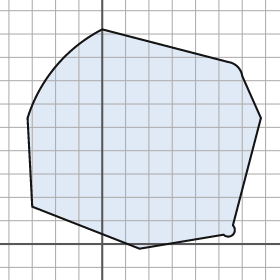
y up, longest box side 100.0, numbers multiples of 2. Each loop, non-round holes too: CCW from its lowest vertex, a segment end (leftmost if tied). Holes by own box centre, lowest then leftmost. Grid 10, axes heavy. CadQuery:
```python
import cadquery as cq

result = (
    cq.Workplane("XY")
    .moveTo(16.0, -2.0)
    .lineTo(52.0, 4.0)
    .threePointArc((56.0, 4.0), (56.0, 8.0))
    .lineTo(68.0, 54.0)
    .lineTo(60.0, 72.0)
    .threePointArc((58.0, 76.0), (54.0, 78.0))
    .lineTo(0.0, 92.0)
    .threePointArc((-20.0, 76.0), (-32.0, 54.0))
    .lineTo(-30.0, 16.0)
    .close()
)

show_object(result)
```